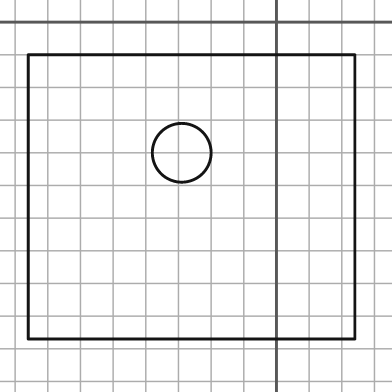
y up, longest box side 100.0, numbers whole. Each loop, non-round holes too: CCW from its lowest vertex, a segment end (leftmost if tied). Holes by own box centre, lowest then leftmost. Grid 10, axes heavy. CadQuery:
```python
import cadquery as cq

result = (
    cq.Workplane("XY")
    .moveTo(-76.0, -97.0)
    .lineTo(24.0, -97.0)
    .lineTo(24.0, -10.0)
    .lineTo(-76.0, -10.0)
    .close()
    .moveTo(-29.0, -40.0)
    .circle(9.0)
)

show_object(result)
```